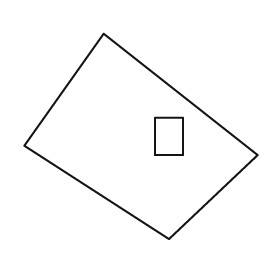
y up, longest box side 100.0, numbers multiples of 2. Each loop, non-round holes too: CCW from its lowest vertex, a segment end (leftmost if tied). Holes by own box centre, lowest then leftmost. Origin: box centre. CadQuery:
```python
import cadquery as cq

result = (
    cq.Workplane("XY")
    .moveTo(12.0, -44.0)
    .lineTo(50.0, -8.0)
    .lineTo(-16.0, 44.0)
    .lineTo(-50.0, -4.0)
    .close()
    .moveTo(6.0, -8.0)
    .lineTo(18.0, -8.0)
    .lineTo(18.0, 8.0)
    .lineTo(6.0, 8.0)
    .close()
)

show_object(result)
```